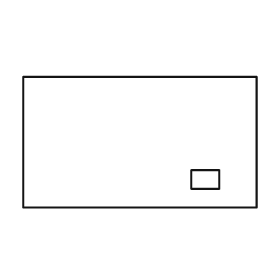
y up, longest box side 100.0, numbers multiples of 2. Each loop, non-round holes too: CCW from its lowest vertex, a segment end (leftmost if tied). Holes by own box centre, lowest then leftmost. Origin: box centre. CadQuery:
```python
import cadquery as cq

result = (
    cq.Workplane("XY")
    .moveTo(-50.0, -28.0)
    .lineTo(50.0, -28.0)
    .lineTo(50.0, 28.0)
    .lineTo(-50.0, 28.0)
    .close()
    .moveTo(22.0, -20.0)
    .lineTo(34.0, -20.0)
    .lineTo(34.0, -12.0)
    .lineTo(22.0, -12.0)
    .close()
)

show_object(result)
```